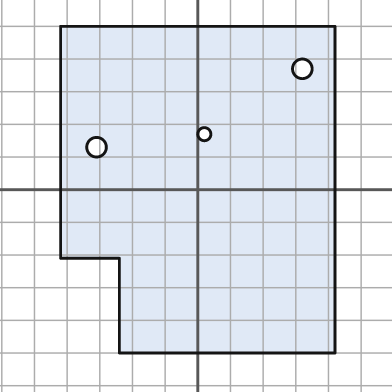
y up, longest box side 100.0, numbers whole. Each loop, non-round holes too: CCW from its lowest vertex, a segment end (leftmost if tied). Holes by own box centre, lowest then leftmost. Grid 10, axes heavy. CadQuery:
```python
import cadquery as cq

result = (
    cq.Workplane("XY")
    .moveTo(-24.0, -50.0)
    .lineTo(42.0, -50.0)
    .lineTo(42.0, 50.0)
    .lineTo(-42.0, 50.0)
    .lineTo(-42.0, -21.0)
    .lineTo(-24.0, -21.0)
    .close()
    .moveTo(-31.0, 13.0)
    .circle(3.0)
    .moveTo(2.0, 17.0)
    .circle(2.0)
    .moveTo(32.0, 37.0)
    .circle(3.0)
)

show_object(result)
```